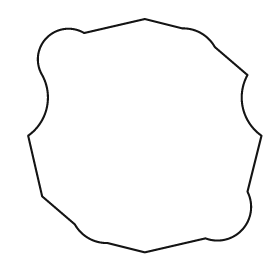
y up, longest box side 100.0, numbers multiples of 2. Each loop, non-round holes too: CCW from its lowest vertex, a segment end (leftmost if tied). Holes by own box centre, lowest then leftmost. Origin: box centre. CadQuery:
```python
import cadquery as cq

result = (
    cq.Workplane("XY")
    .moveTo(0.0, -50.0)
    .lineTo(26.0, -44.0)
    .threePointArc((42.0, -40.0), (44.0, -24.0))
    .lineTo(50.0, 0.0)
    .threePointArc((42.0, 12.0), (44.0, 26.0))
    .lineTo(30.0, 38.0)
    .threePointArc((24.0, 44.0), (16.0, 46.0))
    .lineTo(0.0, 50.0)
    .lineTo(-26.0, 44.0)
    .threePointArc((-42.0, 42.0), (-44.0, 26.0))
    .threePointArc((-42.0, 12.0), (-50.0, 0.0))
    .lineTo(-44.0, -26.0)
    .lineTo(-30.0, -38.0)
    .threePointArc((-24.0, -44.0), (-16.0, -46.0))
    .close()
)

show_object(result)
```